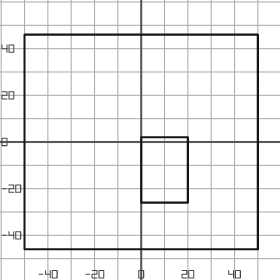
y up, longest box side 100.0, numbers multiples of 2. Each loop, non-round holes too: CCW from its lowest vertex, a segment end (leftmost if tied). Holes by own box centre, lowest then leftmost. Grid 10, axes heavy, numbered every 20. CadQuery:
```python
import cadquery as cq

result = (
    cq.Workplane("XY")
    .moveTo(-50.0, -46.0)
    .lineTo(50.0, -46.0)
    .lineTo(50.0, 46.0)
    .lineTo(-50.0, 46.0)
    .close()
    .moveTo(0.0, -26.0)
    .lineTo(20.0, -26.0)
    .lineTo(20.0, 2.0)
    .lineTo(0.0, 2.0)
    .close()
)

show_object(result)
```